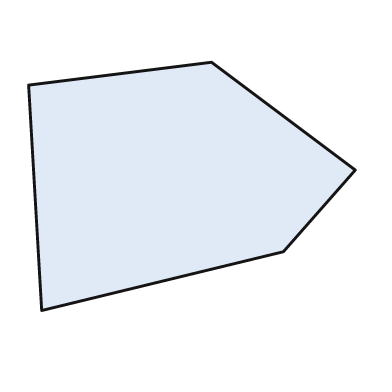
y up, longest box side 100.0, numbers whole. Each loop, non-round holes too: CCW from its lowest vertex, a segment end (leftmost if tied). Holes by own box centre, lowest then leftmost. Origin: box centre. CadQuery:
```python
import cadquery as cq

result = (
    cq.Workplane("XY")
    .moveTo(-46.0, -38.0)
    .lineTo(28.0, -20.0)
    .lineTo(50.0, 5.0)
    .lineTo(6.0, 38.0)
    .lineTo(-50.0, 31.0)
    .close()
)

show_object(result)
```